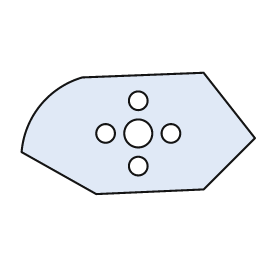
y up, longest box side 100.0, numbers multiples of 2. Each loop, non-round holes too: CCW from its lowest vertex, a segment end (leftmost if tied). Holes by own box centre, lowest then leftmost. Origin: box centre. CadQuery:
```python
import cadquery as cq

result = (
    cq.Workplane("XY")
    .moveTo(-18.0, -26.0)
    .lineTo(28.0, -24.0)
    .lineTo(50.0, -2.0)
    .lineTo(28.0, 26.0)
    .lineTo(-24.0, 24.0)
    .threePointArc((-42.0, 12.0), (-50.0, -8.0))
    .close()
    .moveTo(0.0, -14.0)
    .circle(4.0)
    .moveTo(-14.0, 0.0)
    .circle(4.0)
    .moveTo(0.0, 0.0)
    .circle(6.0)
    .moveTo(14.0, 0.0)
    .circle(4.0)
    .moveTo(0.0, 14.0)
    .circle(4.0)
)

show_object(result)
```